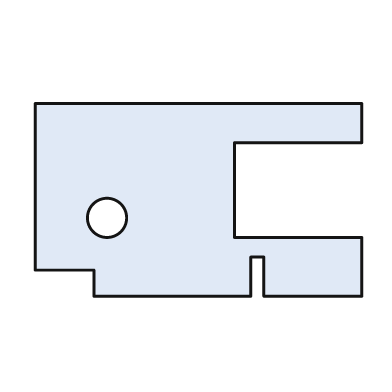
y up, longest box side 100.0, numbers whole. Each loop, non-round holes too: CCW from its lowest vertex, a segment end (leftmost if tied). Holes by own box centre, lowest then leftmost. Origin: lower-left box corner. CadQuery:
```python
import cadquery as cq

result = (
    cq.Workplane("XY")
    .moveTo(18.0, 0.0)
    .lineTo(66.0, 0.0)
    .lineTo(66.0, 12.0)
    .lineTo(70.0, 12.0)
    .lineTo(70.0, 0.0)
    .lineTo(100.0, 0.0)
    .lineTo(100.0, 18.0)
    .lineTo(61.0, 18.0)
    .lineTo(61.0, 47.0)
    .lineTo(100.0, 47.0)
    .lineTo(100.0, 59.0)
    .lineTo(0.0, 59.0)
    .lineTo(0.0, 8.0)
    .lineTo(18.0, 8.0)
    .close()
    .moveTo(22.0, 24.0)
    .circle(6.0)
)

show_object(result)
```